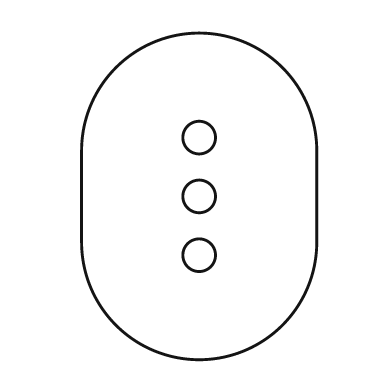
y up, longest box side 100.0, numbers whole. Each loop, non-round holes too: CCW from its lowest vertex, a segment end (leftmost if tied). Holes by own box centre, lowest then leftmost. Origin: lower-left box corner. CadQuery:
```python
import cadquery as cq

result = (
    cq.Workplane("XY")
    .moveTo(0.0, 36.0)
    .threePointArc((36.0, 0.0), (72.0, 36.0))
    .lineTo(72.0, 64.0)
    .threePointArc((36.0, 100.0), (0.0, 64.0))
    .close()
    .moveTo(36.0, 32.0)
    .circle(5.0)
    .moveTo(36.0, 50.0)
    .circle(5.0)
    .moveTo(36.0, 68.0)
    .circle(5.0)
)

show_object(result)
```